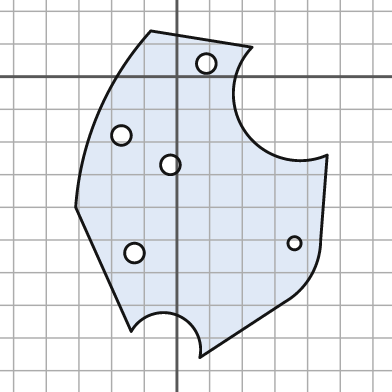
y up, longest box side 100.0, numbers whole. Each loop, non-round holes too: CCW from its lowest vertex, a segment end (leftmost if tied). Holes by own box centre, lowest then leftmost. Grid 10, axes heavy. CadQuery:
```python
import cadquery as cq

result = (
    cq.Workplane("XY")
    .moveTo(7.0, -86.0)
    .lineTo(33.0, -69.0)
    .threePointArc((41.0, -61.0), (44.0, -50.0))
    .lineTo(46.0, -24.0)
    .threePointArc((21.0, -17.0), (23.0, 9.0))
    .lineTo(-8.0, 14.0)
    .threePointArc((-24.0, -11.0), (-31.0, -40.0))
    .lineTo(-14.0, -78.0)
    .threePointArc((0.0, -73.0), (7.0, -86.0))
    .close()
    .moveTo(-13.0, -54.0)
    .circle(3.0)
    .moveTo(36.0, -51.0)
    .circle(2.0)
    .moveTo(-2.0, -27.0)
    .circle(3.0)
    .moveTo(-17.0, -18.0)
    .circle(3.0)
    .moveTo(9.0, 4.0)
    .circle(3.0)
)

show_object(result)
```